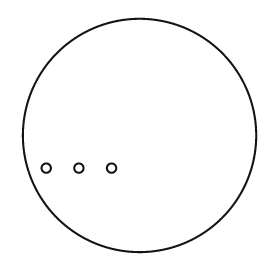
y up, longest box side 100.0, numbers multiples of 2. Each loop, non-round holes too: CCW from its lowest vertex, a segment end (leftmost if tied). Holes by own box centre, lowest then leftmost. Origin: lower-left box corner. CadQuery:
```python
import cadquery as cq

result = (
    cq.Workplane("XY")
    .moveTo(50.0, 50.0)
    .circle(50.0)
    .moveTo(10.0, 36.0)
    .circle(2.0)
    .moveTo(24.0, 36.0)
    .circle(2.0)
    .moveTo(38.0, 36.0)
    .circle(2.0)
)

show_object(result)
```